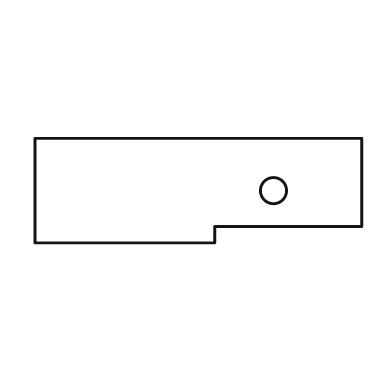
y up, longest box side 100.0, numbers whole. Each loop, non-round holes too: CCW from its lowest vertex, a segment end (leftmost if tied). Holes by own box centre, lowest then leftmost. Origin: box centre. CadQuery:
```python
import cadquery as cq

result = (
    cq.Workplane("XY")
    .moveTo(-50.0, -16.0)
    .lineTo(5.0, -16.0)
    .lineTo(5.0, -11.0)
    .lineTo(50.0, -11.0)
    .lineTo(50.0, 16.0)
    .lineTo(-50.0, 16.0)
    .close()
    .moveTo(23.0, 0.0)
    .circle(4.0)
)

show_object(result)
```